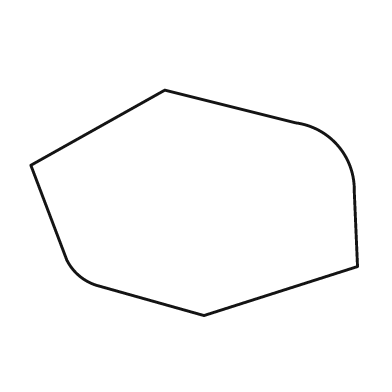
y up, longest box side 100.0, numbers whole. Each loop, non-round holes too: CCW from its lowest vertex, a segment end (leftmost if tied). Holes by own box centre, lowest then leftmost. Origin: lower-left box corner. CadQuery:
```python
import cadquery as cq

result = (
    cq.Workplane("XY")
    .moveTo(53.0, 0.0)
    .lineTo(100.0, 15.0)
    .lineTo(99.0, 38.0)
    .threePointArc((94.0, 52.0), (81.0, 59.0))
    .lineTo(41.0, 69.0)
    .lineTo(0.0, 46.0)
    .lineTo(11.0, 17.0)
    .threePointArc((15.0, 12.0), (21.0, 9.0))
    .close()
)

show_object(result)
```